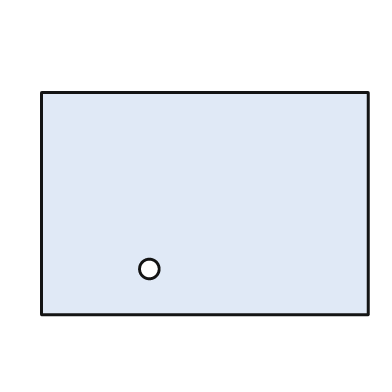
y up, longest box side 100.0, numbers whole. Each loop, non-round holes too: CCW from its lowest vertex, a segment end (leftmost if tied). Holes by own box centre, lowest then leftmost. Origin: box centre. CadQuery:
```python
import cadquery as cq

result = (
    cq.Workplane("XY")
    .moveTo(-50.0, -34.0)
    .lineTo(50.0, -34.0)
    .lineTo(50.0, 34.0)
    .lineTo(-50.0, 34.0)
    .close()
    .moveTo(-17.0, -20.0)
    .circle(3.0)
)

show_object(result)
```